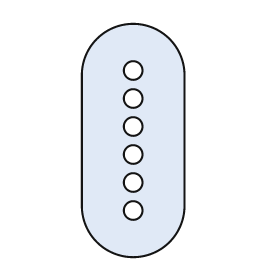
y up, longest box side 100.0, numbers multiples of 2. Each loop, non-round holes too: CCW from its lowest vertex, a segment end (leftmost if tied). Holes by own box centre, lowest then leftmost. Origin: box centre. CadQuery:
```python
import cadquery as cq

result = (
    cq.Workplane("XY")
    .moveTo(-22.0, -28.0)
    .threePointArc((0.0, -50.0), (22.0, -28.0))
    .lineTo(22.0, 28.0)
    .threePointArc((0.0, 50.0), (-22.0, 28.0))
    .close()
    .moveTo(0.0, -30.0)
    .circle(4.0)
    .moveTo(0.0, -18.0)
    .circle(4.0)
    .moveTo(0.0, -6.0)
    .circle(4.0)
    .moveTo(0.0, 6.0)
    .circle(4.0)
    .moveTo(0.0, 18.0)
    .circle(4.0)
    .moveTo(0.0, 30.0)
    .circle(4.0)
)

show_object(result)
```